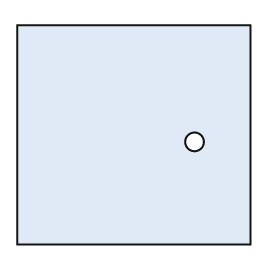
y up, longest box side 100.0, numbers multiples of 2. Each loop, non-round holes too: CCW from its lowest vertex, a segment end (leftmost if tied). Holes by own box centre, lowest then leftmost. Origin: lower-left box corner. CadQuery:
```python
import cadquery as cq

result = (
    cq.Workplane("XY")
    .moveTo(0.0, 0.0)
    .lineTo(100.0, 0.0)
    .lineTo(100.0, 94.0)
    .lineTo(0.0, 94.0)
    .close()
    .moveTo(76.0, 44.0)
    .circle(4.0)
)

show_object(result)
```